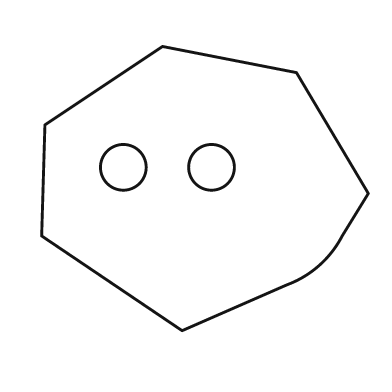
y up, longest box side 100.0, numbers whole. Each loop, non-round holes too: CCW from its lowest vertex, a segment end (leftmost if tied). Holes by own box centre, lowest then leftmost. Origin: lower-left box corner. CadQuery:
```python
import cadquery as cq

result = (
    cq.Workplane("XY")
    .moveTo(43.0, 0.0)
    .lineTo(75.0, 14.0)
    .threePointArc((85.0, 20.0), (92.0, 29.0))
    .lineTo(100.0, 42.0)
    .lineTo(78.0, 79.0)
    .lineTo(37.0, 87.0)
    .lineTo(1.0, 63.0)
    .lineTo(0.0, 29.0)
    .close()
    .moveTo(25.0, 50.0)
    .circle(7.0)
    .moveTo(52.0, 50.0)
    .circle(7.0)
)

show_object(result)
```